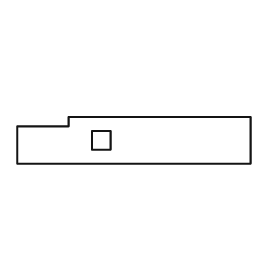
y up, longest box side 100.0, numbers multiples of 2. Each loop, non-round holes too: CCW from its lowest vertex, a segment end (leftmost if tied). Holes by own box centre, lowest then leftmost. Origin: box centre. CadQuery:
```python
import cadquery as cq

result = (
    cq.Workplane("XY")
    .moveTo(-50.0, -10.0)
    .lineTo(50.0, -10.0)
    .lineTo(50.0, 10.0)
    .lineTo(-28.0, 10.0)
    .lineTo(-28.0, 6.0)
    .lineTo(-50.0, 6.0)
    .close()
    .moveTo(-18.0, -4.0)
    .lineTo(-10.0, -4.0)
    .lineTo(-10.0, 4.0)
    .lineTo(-18.0, 4.0)
    .close()
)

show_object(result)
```